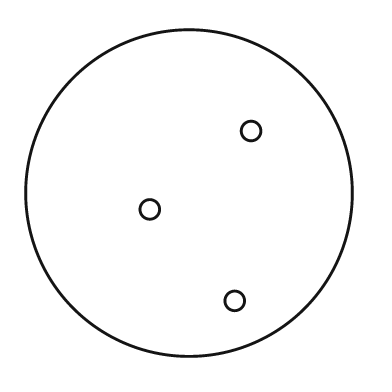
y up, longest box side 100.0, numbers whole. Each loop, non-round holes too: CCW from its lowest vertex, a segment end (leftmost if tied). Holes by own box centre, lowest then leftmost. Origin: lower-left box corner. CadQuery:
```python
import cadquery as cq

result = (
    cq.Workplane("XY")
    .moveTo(50.0, 50.0)
    .circle(50.0)
    .moveTo(64.0, 17.0)
    .circle(3.0)
    .moveTo(38.0, 45.0)
    .circle(3.0)
    .moveTo(69.0, 69.0)
    .circle(3.0)
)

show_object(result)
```